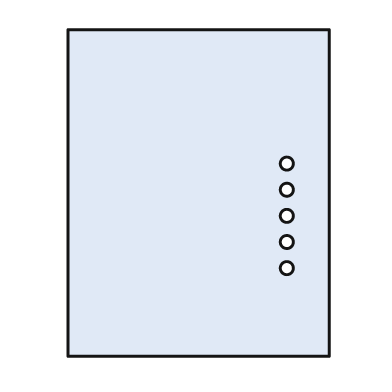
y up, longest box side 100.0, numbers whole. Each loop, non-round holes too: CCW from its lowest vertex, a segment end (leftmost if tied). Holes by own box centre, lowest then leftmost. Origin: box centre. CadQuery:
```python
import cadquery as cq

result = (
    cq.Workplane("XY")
    .moveTo(-40.0, -50.0)
    .lineTo(40.0, -50.0)
    .lineTo(40.0, 50.0)
    .lineTo(-40.0, 50.0)
    .close()
    .moveTo(27.0, -23.0)
    .circle(2.0)
    .moveTo(27.0, -15.0)
    .circle(2.0)
    .moveTo(27.0, -7.0)
    .circle(2.0)
    .moveTo(27.0, 1.0)
    .circle(2.0)
    .moveTo(27.0, 9.0)
    .circle(2.0)
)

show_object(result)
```